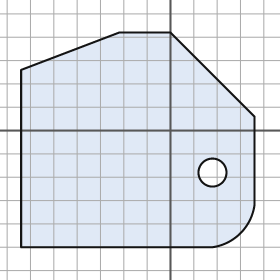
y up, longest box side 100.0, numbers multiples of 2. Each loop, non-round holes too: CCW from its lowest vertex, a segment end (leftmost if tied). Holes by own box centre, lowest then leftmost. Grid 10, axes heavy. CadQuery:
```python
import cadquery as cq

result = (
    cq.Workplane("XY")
    .moveTo(-64.0, -50.0)
    .lineTo(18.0, -50.0)
    .threePointArc((30.0, -44.0), (36.0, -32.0))
    .lineTo(36.0, 6.0)
    .lineTo(0.0, 42.0)
    .lineTo(-22.0, 42.0)
    .lineTo(-64.0, 26.0)
    .close()
    .moveTo(18.0, -18.0)
    .circle(6.0)
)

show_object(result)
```